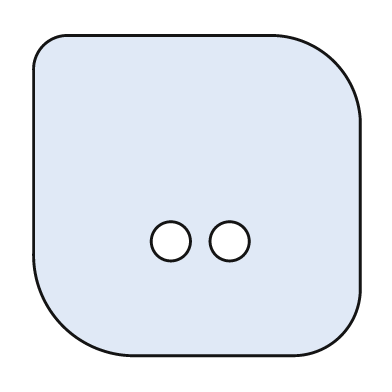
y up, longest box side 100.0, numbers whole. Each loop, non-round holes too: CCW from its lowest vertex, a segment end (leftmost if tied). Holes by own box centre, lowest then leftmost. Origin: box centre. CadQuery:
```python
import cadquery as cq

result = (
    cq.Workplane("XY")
    .moveTo(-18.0, -49.0)
    .lineTo(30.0, -49.0)
    .threePointArc((44.0, -43.0), (50.0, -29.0))
    .lineTo(50.0, 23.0)
    .threePointArc((42.0, 41.0), (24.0, 49.0))
    .lineTo(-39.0, 49.0)
    .threePointArc((-47.0, 46.0), (-50.0, 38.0))
    .lineTo(-50.0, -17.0)
    .threePointArc((-41.0, -40.0), (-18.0, -49.0))
    .close()
    .moveTo(-8.0, -14.0)
    .circle(6.0)
    .moveTo(10.0, -14.0)
    .circle(6.0)
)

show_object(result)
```